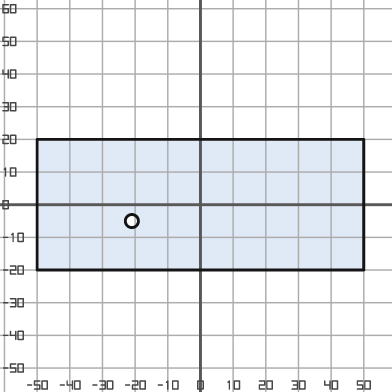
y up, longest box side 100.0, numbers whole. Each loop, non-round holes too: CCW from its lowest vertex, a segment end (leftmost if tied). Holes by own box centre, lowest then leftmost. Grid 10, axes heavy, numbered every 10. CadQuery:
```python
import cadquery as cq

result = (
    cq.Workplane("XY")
    .moveTo(-50.0, -20.0)
    .lineTo(50.0, -20.0)
    .lineTo(50.0, 20.0)
    .lineTo(-50.0, 20.0)
    .close()
    .moveTo(-21.0, -5.0)
    .circle(2.0)
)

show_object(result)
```